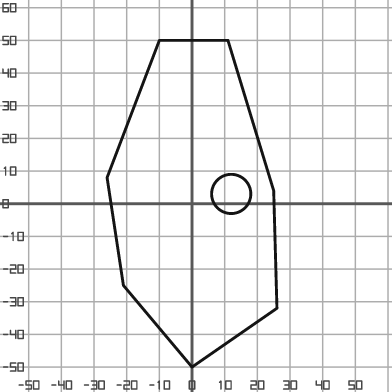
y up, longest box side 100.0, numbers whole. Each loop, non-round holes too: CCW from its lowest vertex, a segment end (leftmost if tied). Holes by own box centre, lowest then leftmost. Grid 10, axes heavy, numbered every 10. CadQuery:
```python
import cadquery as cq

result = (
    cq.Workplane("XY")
    .moveTo(0.0, -50.0)
    .lineTo(26.0, -32.0)
    .lineTo(25.0, 4.0)
    .lineTo(11.0, 50.0)
    .lineTo(-10.0, 50.0)
    .lineTo(-26.0, 8.0)
    .lineTo(-21.0, -25.0)
    .close()
    .moveTo(12.0, 3.0)
    .circle(6.0)
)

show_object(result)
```